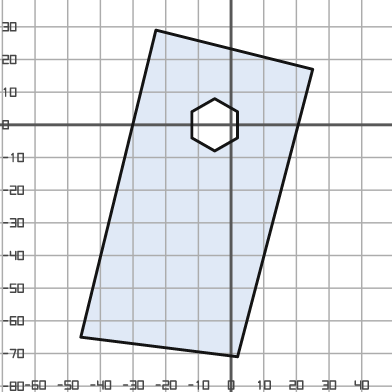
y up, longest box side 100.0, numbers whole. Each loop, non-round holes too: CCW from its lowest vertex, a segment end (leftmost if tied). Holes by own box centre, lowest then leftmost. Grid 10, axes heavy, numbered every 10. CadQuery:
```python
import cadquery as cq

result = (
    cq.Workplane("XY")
    .moveTo(2.0, -71.0)
    .lineTo(25.0, 17.0)
    .lineTo(-23.0, 29.0)
    .lineTo(-46.0, -65.0)
    .close()
    .moveTo(-5.0, -8.0)
    .lineTo(2.0, -4.0)
    .lineTo(2.0, 4.0)
    .lineTo(-5.0, 8.0)
    .lineTo(-12.0, 4.0)
    .lineTo(-12.0, -4.0)
    .close()
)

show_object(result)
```